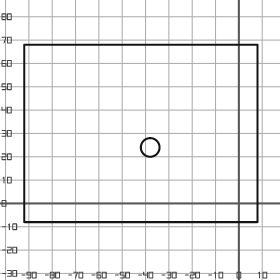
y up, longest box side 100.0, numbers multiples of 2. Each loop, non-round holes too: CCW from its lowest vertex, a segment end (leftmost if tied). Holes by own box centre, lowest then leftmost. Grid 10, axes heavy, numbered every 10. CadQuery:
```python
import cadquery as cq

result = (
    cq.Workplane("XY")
    .moveTo(-92.0, -8.0)
    .lineTo(8.0, -8.0)
    .lineTo(8.0, 68.0)
    .lineTo(-92.0, 68.0)
    .close()
    .moveTo(-38.0, 24.0)
    .circle(4.0)
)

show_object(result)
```